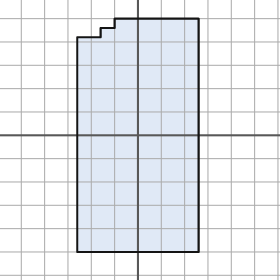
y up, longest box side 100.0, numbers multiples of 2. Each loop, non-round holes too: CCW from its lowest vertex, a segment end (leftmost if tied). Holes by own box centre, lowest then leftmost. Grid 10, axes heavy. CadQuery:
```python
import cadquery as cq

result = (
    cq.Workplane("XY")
    .moveTo(-26.0, -50.0)
    .lineTo(26.0, -50.0)
    .lineTo(26.0, 50.0)
    .lineTo(-10.0, 50.0)
    .lineTo(-10.0, 46.0)
    .lineTo(-16.0, 46.0)
    .lineTo(-16.0, 42.0)
    .lineTo(-26.0, 42.0)
    .close()
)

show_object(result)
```